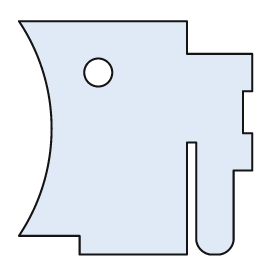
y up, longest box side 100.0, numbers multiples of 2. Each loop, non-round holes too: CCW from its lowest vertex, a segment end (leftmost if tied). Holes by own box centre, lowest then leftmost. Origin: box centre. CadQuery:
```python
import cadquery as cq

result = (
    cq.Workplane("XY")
    .moveTo(-24.0, -50.0)
    .lineTo(22.0, -50.0)
    .lineTo(22.0, -2.0)
    .lineTo(26.0, -2.0)
    .lineTo(26.0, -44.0)
    .threePointArc((28.0, -48.0), (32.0, -50.0))
    .lineTo(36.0, -50.0)
    .threePointArc((40.0, -48.0), (42.0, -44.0))
    .lineTo(42.0, -14.0)
    .lineTo(50.0, -14.0)
    .lineTo(50.0, 2.0)
    .lineTo(46.0, 2.0)
    .lineTo(46.0, 20.0)
    .lineTo(50.0, 20.0)
    .lineTo(50.0, 36.0)
    .lineTo(22.0, 36.0)
    .lineTo(22.0, 50.0)
    .lineTo(-50.0, 50.0)
    .threePointArc((-36.0, 4.0), (-50.0, -42.0))
    .lineTo(-24.0, -42.0)
    .close()
    .moveTo(-16.0, 28.0)
    .circle(6.0)
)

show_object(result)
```